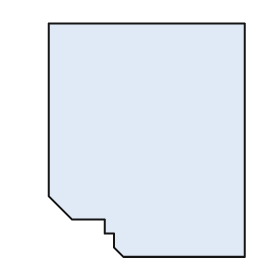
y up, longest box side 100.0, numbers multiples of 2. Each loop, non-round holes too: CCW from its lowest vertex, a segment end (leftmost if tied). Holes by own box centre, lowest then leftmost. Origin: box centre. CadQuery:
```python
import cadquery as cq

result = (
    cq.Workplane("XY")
    .moveTo(-10.0, -50.0)
    .lineTo(42.0, -50.0)
    .lineTo(42.0, 50.0)
    .lineTo(-42.0, 50.0)
    .lineTo(-42.0, -24.0)
    .lineTo(-32.0, -34.0)
    .lineTo(-18.0, -34.0)
    .lineTo(-18.0, -40.0)
    .lineTo(-14.0, -40.0)
    .lineTo(-14.0, -46.0)
    .close()
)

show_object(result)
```